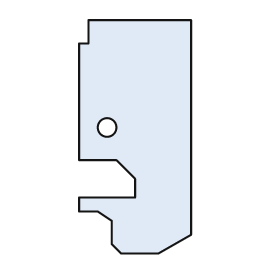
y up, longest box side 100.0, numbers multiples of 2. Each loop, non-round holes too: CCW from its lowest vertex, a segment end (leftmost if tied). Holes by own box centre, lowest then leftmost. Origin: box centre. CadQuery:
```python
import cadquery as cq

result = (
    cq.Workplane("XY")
    .moveTo(-6.0, -50.0)
    .lineTo(10.0, -50.0)
    .lineTo(24.0, -42.0)
    .lineTo(24.0, 50.0)
    .lineTo(-20.0, 50.0)
    .lineTo(-20.0, 40.0)
    .lineTo(-24.0, 40.0)
    .lineTo(-24.0, -10.0)
    .lineTo(-8.0, -10.0)
    .lineTo(0.0, -18.0)
    .lineTo(0.0, -26.0)
    .lineTo(-24.0, -26.0)
    .lineTo(-24.0, -32.0)
    .lineTo(-16.0, -32.0)
    .lineTo(-10.0, -36.0)
    .lineTo(-10.0, -46.0)
    .close()
    .moveTo(-12.0, 4.0)
    .circle(4.0)
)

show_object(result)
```